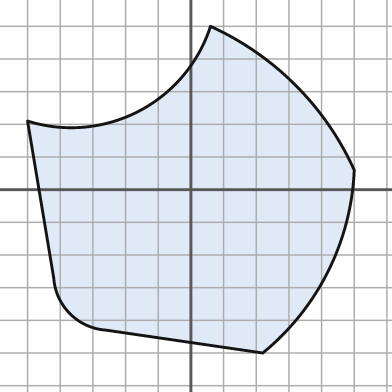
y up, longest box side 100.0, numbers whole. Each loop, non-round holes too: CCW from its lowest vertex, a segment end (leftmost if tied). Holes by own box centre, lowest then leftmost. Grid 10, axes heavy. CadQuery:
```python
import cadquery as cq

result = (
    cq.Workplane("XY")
    .moveTo(22.0, -50.0)
    .threePointArc((42.0, -25.0), (50.0, 6.0))
    .threePointArc((32.0, 32.0), (6.0, 50.0))
    .threePointArc((-16.0, 24.0), (-50.0, 21.0))
    .lineTo(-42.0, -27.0)
    .threePointArc((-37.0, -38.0), (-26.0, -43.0))
    .close()
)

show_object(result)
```